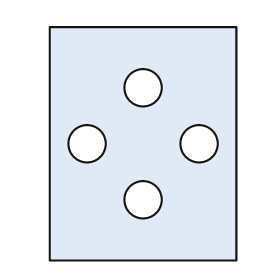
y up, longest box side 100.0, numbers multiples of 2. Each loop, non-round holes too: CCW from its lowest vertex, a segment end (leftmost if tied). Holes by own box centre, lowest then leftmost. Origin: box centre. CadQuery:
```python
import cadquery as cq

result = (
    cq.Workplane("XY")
    .moveTo(-40.0, -50.0)
    .lineTo(40.0, -50.0)
    .lineTo(40.0, 50.0)
    .lineTo(-40.0, 50.0)
    .close()
    .moveTo(0.0, -24.0)
    .circle(8.0)
    .moveTo(-24.0, 0.0)
    .circle(8.0)
    .moveTo(24.0, 0.0)
    .circle(8.0)
    .moveTo(0.0, 24.0)
    .circle(8.0)
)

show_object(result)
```